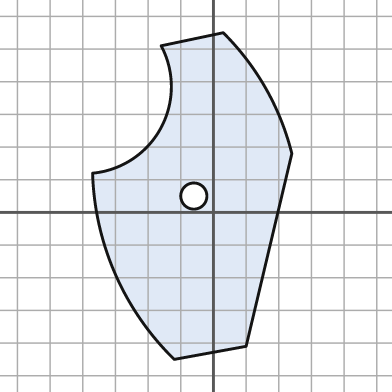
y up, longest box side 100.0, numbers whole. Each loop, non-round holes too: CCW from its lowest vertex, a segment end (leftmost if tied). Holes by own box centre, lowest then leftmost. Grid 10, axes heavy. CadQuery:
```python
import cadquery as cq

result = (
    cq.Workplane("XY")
    .moveTo(-12.0, -45.0)
    .lineTo(10.0, -41.0)
    .lineTo(24.0, 18.0)
    .threePointArc((16.0, 38.0), (3.0, 55.0))
    .lineTo(-16.0, 51.0)
    .threePointArc((-16.0, 26.0), (-37.0, 12.0))
    .threePointArc((-30.0, -19.0), (-12.0, -45.0))
    .close()
    .moveTo(-6.0, 5.0)
    .circle(4.0)
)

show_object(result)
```